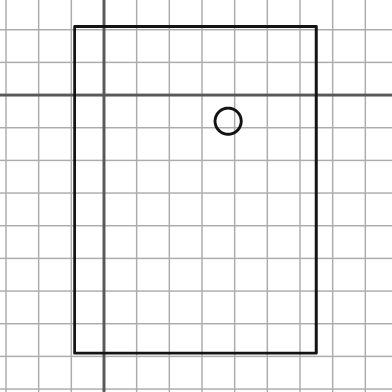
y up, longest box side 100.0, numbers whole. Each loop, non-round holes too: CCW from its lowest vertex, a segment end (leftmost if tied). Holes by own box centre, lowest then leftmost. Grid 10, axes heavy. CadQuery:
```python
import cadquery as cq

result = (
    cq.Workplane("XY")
    .moveTo(-9.0, -79.0)
    .lineTo(65.0, -79.0)
    .lineTo(65.0, 21.0)
    .lineTo(-9.0, 21.0)
    .close()
    .moveTo(38.0, -8.0)
    .circle(4.0)
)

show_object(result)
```